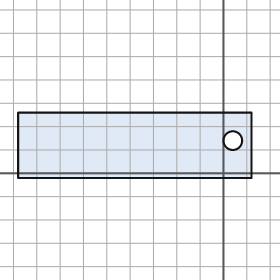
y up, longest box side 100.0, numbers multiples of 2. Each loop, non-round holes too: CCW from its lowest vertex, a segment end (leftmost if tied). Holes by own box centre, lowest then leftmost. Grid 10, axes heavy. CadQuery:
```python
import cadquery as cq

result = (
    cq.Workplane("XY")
    .moveTo(-88.0, -2.0)
    .lineTo(12.0, -2.0)
    .lineTo(12.0, 26.0)
    .lineTo(-88.0, 26.0)
    .close()
    .moveTo(4.0, 14.0)
    .circle(4.0)
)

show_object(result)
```